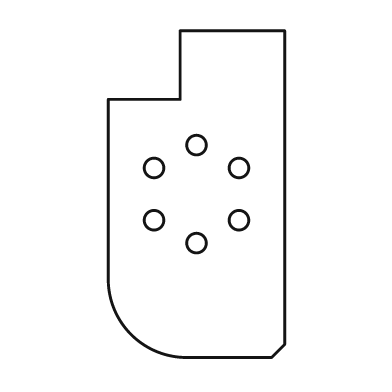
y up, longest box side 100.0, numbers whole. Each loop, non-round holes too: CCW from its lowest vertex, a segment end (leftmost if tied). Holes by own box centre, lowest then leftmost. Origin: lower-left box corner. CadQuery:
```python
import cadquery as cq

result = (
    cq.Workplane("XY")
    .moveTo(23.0, 0.0)
    .lineTo(50.0, 0.0)
    .lineTo(54.0, 4.0)
    .lineTo(54.0, 100.0)
    .lineTo(22.0, 100.0)
    .lineTo(22.0, 79.0)
    .lineTo(0.0, 79.0)
    .lineTo(0.0, 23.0)
    .threePointArc((7.0, 7.0), (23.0, 0.0))
    .close()
    .moveTo(27.0, 35.0)
    .circle(3.0)
    .moveTo(14.0, 42.0)
    .circle(3.0)
    .moveTo(40.0, 42.0)
    .circle(3.0)
    .moveTo(14.0, 58.0)
    .circle(3.0)
    .moveTo(40.0, 58.0)
    .circle(3.0)
    .moveTo(27.0, 65.0)
    .circle(3.0)
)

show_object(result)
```